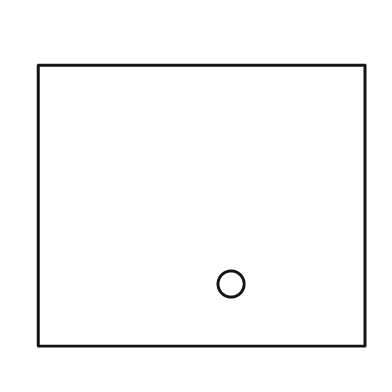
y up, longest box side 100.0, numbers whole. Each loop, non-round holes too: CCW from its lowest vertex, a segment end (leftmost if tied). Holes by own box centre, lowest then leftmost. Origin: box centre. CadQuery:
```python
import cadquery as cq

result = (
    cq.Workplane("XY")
    .moveTo(-50.0, -43.0)
    .lineTo(50.0, -43.0)
    .lineTo(50.0, 43.0)
    .lineTo(-50.0, 43.0)
    .close()
    .moveTo(9.0, -24.0)
    .circle(4.0)
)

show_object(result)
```